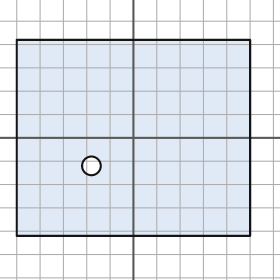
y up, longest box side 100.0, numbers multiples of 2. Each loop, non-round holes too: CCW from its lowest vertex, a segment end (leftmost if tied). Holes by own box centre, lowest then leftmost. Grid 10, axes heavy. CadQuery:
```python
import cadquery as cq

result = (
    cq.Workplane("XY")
    .moveTo(-50.0, -42.0)
    .lineTo(50.0, -42.0)
    .lineTo(50.0, 42.0)
    .lineTo(-50.0, 42.0)
    .close()
    .moveTo(-18.0, -12.0)
    .circle(4.0)
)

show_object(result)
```